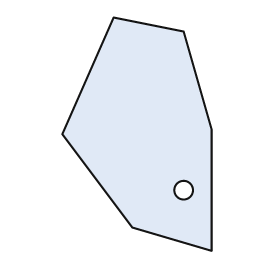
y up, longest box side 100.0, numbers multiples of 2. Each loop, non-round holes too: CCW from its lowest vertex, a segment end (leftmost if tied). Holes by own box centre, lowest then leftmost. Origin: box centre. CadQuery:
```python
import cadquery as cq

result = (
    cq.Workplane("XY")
    .moveTo(32.0, -50.0)
    .lineTo(32.0, 2.0)
    .lineTo(20.0, 44.0)
    .lineTo(-10.0, 50.0)
    .lineTo(-32.0, 0.0)
    .lineTo(-2.0, -40.0)
    .close()
    .moveTo(20.0, -24.0)
    .circle(4.0)
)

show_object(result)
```